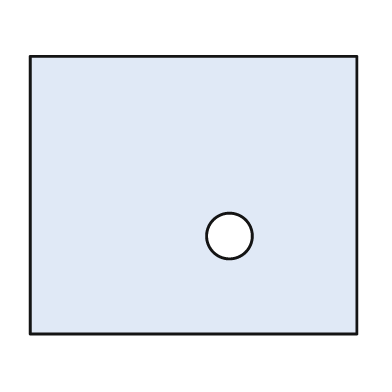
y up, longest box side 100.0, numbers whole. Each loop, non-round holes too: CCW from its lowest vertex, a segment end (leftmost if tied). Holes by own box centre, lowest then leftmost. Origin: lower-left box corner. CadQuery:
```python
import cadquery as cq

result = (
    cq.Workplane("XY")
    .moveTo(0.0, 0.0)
    .lineTo(100.0, 0.0)
    .lineTo(100.0, 85.0)
    .lineTo(0.0, 85.0)
    .close()
    .moveTo(61.0, 30.0)
    .circle(7.0)
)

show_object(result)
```